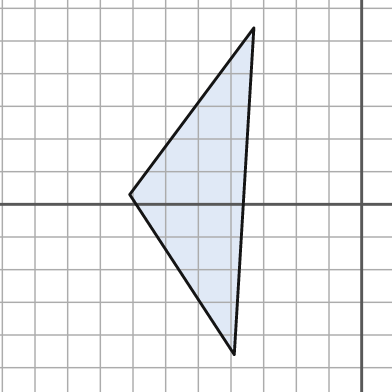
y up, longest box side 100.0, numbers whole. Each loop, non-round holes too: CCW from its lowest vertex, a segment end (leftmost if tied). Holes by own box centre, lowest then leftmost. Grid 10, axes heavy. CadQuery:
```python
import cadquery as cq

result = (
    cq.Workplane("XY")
    .moveTo(-39.0, -46.0)
    .lineTo(-33.0, 54.0)
    .lineTo(-71.0, 3.0)
    .close()
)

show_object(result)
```